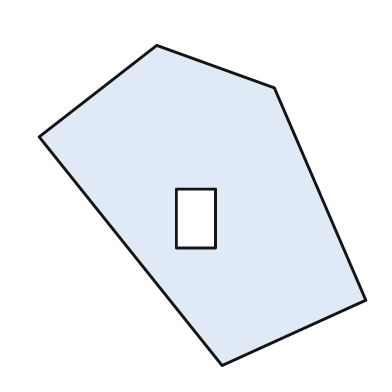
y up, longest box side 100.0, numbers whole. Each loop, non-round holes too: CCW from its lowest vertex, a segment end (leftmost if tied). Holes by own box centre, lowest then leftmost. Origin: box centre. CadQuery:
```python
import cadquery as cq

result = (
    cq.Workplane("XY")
    .moveTo(6.0, -49.0)
    .lineTo(50.0, -29.0)
    .lineTo(22.0, 36.0)
    .lineTo(-14.0, 49.0)
    .lineTo(-50.0, 21.0)
    .close()
    .moveTo(-8.0, -13.0)
    .lineTo(4.0, -13.0)
    .lineTo(4.0, 5.0)
    .lineTo(-8.0, 5.0)
    .close()
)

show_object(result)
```